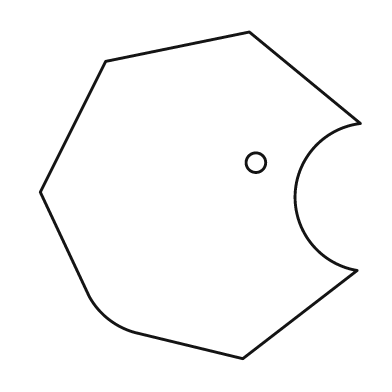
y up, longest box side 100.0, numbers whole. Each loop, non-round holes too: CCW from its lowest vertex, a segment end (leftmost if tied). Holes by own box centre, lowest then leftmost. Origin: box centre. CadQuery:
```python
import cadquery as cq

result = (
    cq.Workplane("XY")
    .moveTo(13.0, -50.0)
    .lineTo(48.0, -23.0)
    .threePointArc((29.0, 0.0), (49.0, 22.0))
    .lineTo(15.0, 50.0)
    .lineTo(-29.0, 41.0)
    .lineTo(-49.0, 1.0)
    .lineTo(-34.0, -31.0)
    .threePointArc((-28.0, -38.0), (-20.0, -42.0))
    .close()
    .moveTo(17.0, 10.0)
    .circle(3.0)
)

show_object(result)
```